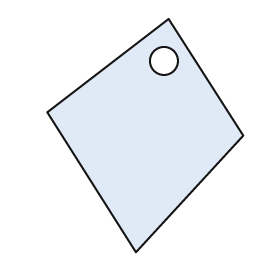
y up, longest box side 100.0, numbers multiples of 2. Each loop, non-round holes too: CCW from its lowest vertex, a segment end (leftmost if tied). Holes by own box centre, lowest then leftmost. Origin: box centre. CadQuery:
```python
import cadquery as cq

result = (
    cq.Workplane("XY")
    .moveTo(-4.0, -50.0)
    .lineTo(42.0, 0.0)
    .lineTo(10.0, 50.0)
    .lineTo(-42.0, 10.0)
    .close()
    .moveTo(8.0, 32.0)
    .circle(6.0)
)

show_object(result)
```